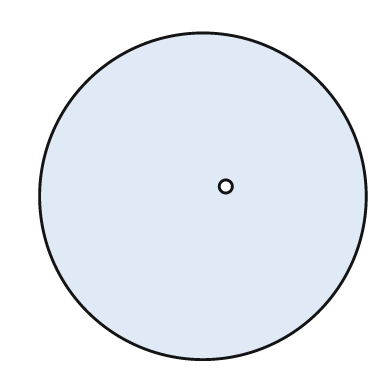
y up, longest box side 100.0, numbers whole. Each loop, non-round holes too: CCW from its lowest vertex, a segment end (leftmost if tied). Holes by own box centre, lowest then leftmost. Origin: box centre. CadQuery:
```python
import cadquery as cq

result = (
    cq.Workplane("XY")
    .moveTo(0.0, 0.0)
    .circle(50.0)
    .moveTo(7.0, 3.0)
    .circle(2.0)
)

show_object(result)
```